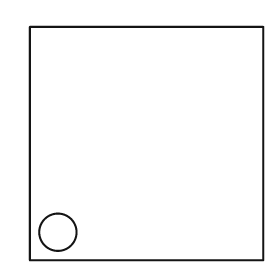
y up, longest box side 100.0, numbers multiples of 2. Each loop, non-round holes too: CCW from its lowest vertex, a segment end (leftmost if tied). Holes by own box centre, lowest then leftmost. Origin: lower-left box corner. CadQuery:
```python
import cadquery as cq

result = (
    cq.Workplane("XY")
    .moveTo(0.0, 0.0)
    .lineTo(100.0, 0.0)
    .lineTo(100.0, 100.0)
    .lineTo(0.0, 100.0)
    .close()
    .moveTo(12.0, 12.0)
    .circle(8.0)
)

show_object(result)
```